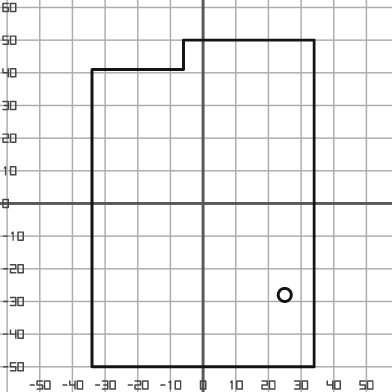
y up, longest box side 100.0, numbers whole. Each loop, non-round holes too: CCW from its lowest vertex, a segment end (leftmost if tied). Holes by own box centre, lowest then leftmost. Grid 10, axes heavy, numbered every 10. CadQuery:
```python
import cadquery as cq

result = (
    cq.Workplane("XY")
    .moveTo(-34.0, -50.0)
    .lineTo(34.0, -50.0)
    .lineTo(34.0, 50.0)
    .lineTo(-6.0, 50.0)
    .lineTo(-6.0, 41.0)
    .lineTo(-34.0, 41.0)
    .close()
    .moveTo(25.0, -28.0)
    .circle(2.0)
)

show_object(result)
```